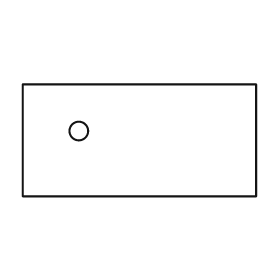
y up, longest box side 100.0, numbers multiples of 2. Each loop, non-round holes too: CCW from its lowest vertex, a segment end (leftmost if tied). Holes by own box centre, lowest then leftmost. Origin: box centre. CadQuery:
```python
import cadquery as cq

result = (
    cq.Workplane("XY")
    .moveTo(-50.0, -24.0)
    .lineTo(50.0, -24.0)
    .lineTo(50.0, 24.0)
    .lineTo(-50.0, 24.0)
    .close()
    .moveTo(-26.0, 4.0)
    .circle(4.0)
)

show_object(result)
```